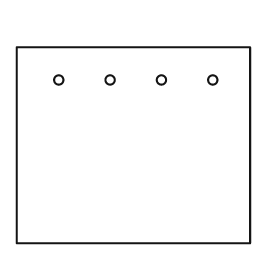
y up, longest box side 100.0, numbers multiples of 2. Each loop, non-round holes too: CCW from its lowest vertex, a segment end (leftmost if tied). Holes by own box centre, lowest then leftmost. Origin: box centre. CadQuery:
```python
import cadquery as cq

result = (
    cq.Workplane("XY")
    .moveTo(-50.0, -42.0)
    .lineTo(50.0, -42.0)
    .lineTo(50.0, 42.0)
    .lineTo(-50.0, 42.0)
    .close()
    .moveTo(-32.0, 28.0)
    .circle(2.0)
    .moveTo(-10.0, 28.0)
    .circle(2.0)
    .moveTo(12.0, 28.0)
    .circle(2.0)
    .moveTo(34.0, 28.0)
    .circle(2.0)
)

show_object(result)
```